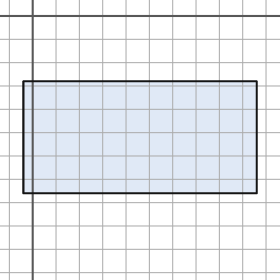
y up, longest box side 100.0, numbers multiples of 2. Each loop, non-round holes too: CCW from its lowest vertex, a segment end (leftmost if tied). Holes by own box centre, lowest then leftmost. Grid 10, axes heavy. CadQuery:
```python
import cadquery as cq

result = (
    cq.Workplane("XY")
    .moveTo(-4.0, -76.0)
    .lineTo(96.0, -76.0)
    .lineTo(96.0, -28.0)
    .lineTo(-4.0, -28.0)
    .close()
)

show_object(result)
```